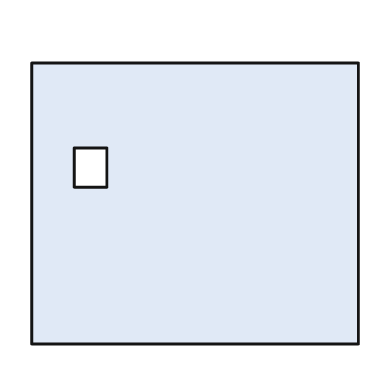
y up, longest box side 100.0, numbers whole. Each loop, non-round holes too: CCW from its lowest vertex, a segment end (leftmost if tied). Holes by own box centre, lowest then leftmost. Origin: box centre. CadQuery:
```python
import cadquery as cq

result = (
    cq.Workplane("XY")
    .moveTo(-50.0, -43.0)
    .lineTo(50.0, -43.0)
    .lineTo(50.0, 43.0)
    .lineTo(-50.0, 43.0)
    .close()
    .moveTo(-37.0, 5.0)
    .lineTo(-27.0, 5.0)
    .lineTo(-27.0, 17.0)
    .lineTo(-37.0, 17.0)
    .close()
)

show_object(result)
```